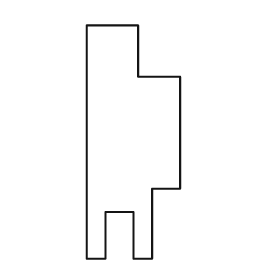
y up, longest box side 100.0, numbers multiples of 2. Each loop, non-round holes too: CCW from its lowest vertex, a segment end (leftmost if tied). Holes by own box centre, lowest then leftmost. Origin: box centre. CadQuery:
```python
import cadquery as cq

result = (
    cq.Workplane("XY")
    .moveTo(-20.0, -50.0)
    .lineTo(-12.0, -50.0)
    .lineTo(-12.0, -30.0)
    .lineTo(0.0, -30.0)
    .lineTo(0.0, -50.0)
    .lineTo(8.0, -50.0)
    .lineTo(8.0, -20.0)
    .lineTo(20.0, -20.0)
    .lineTo(20.0, 28.0)
    .lineTo(2.0, 28.0)
    .lineTo(2.0, 50.0)
    .lineTo(-20.0, 50.0)
    .close()
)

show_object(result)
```